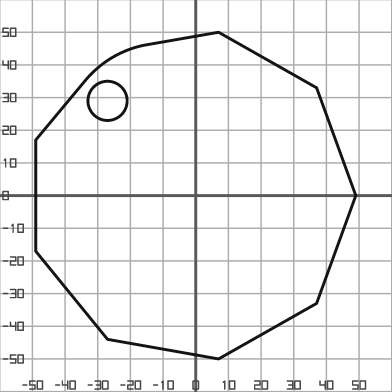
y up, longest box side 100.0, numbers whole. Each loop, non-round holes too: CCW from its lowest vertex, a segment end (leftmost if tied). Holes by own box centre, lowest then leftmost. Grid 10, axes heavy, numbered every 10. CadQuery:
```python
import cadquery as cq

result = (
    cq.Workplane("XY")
    .moveTo(7.0, -50.0)
    .lineTo(37.0, -33.0)
    .lineTo(49.0, 0.0)
    .lineTo(37.0, 33.0)
    .lineTo(7.0, 50.0)
    .lineTo(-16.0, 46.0)
    .threePointArc((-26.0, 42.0), (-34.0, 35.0))
    .lineTo(-49.0, 17.0)
    .lineTo(-49.0, -17.0)
    .lineTo(-27.0, -44.0)
    .close()
    .moveTo(-27.0, 29.0)
    .circle(6.0)
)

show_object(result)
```